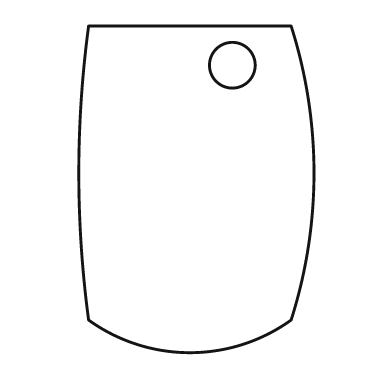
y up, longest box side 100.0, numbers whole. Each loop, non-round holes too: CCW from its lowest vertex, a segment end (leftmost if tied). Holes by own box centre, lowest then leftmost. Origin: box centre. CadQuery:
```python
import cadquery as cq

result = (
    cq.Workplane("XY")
    .moveTo(-33.0, -40.0)
    .threePointArc((-2.0, -50.0), (29.0, -40.0))
    .threePointArc((36.0, 5.0), (29.0, 50.0))
    .lineTo(-33.0, 50.0)
    .threePointArc((-36.0, 5.0), (-33.0, -40.0))
    .close()
    .moveTo(11.0, 38.0)
    .circle(7.0)
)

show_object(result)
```